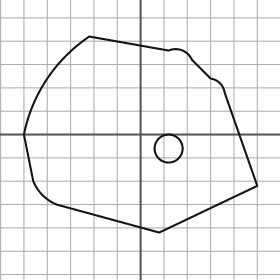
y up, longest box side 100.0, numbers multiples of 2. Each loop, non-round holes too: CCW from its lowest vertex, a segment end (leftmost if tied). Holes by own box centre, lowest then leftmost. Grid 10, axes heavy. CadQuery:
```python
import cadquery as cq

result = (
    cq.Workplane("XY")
    .moveTo(8.0, -42.0)
    .lineTo(50.0, -22.0)
    .lineTo(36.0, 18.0)
    .threePointArc((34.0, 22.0), (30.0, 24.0))
    .lineTo(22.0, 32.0)
    .threePointArc((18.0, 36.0), (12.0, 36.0))
    .lineTo(-22.0, 42.0)
    .threePointArc((-40.0, 24.0), (-50.0, 0.0))
    .lineTo(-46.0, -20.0)
    .threePointArc((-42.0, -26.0), (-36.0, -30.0))
    .close()
    .moveTo(12.0, -6.0)
    .circle(6.0)
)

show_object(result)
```